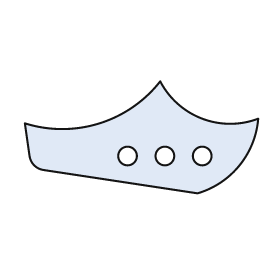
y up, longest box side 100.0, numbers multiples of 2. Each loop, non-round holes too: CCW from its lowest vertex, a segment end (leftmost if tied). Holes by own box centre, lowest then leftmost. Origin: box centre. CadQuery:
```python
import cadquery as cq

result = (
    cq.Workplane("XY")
    .moveTo(24.0, -24.0)
    .threePointArc((42.0, -12.0), (50.0, 8.0))
    .threePointArc((26.0, 8.0), (8.0, 24.0))
    .threePointArc((-18.0, 6.0), (-50.0, 6.0))
    .lineTo(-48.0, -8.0)
    .threePointArc((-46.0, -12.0), (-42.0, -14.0))
    .close()
    .moveTo(-6.0, -8.0)
    .circle(4.0)
    .moveTo(10.0, -8.0)
    .circle(4.0)
    .moveTo(26.0, -8.0)
    .circle(4.0)
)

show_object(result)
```